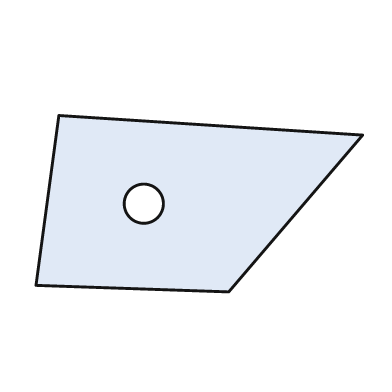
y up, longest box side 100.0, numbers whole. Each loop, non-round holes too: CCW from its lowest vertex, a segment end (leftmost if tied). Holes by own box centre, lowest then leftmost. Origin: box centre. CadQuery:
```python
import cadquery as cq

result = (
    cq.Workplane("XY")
    .moveTo(9.0, -27.0)
    .lineTo(50.0, 21.0)
    .lineTo(-43.0, 27.0)
    .lineTo(-50.0, -25.0)
    .close()
    .moveTo(-17.0, 0.0)
    .circle(6.0)
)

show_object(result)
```